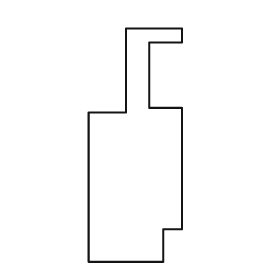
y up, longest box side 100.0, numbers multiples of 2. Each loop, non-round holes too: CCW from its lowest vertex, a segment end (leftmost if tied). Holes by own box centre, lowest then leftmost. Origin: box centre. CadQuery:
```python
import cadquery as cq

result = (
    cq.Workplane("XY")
    .moveTo(-20.0, -50.0)
    .lineTo(12.0, -50.0)
    .lineTo(12.0, -36.0)
    .lineTo(20.0, -36.0)
    .lineTo(20.0, 16.0)
    .lineTo(6.0, 16.0)
    .lineTo(6.0, 44.0)
    .lineTo(20.0, 44.0)
    .lineTo(20.0, 50.0)
    .lineTo(-4.0, 50.0)
    .lineTo(-4.0, 14.0)
    .lineTo(-20.0, 14.0)
    .close()
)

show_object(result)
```